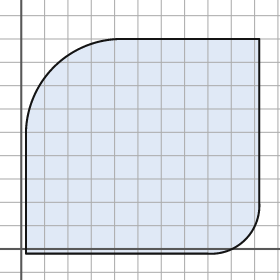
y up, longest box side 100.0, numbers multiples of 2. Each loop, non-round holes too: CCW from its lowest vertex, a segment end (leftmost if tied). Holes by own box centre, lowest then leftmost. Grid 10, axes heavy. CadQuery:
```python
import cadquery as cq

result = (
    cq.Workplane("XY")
    .moveTo(2.0, -2.0)
    .lineTo(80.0, -2.0)
    .threePointArc((96.0, 4.0), (102.0, 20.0))
    .lineTo(102.0, 90.0)
    .lineTo(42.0, 90.0)
    .threePointArc((14.0, 78.0), (2.0, 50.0))
    .close()
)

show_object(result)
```